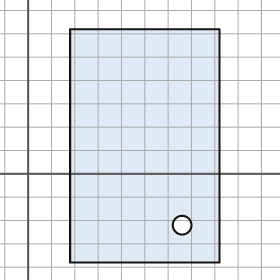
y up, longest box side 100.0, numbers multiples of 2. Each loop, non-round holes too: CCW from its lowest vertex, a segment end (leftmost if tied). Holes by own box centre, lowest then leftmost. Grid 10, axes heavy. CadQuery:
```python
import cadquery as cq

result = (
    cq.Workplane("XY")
    .moveTo(18.0, -38.0)
    .lineTo(82.0, -38.0)
    .lineTo(82.0, 62.0)
    .lineTo(18.0, 62.0)
    .close()
    .moveTo(66.0, -22.0)
    .circle(4.0)
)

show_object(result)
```